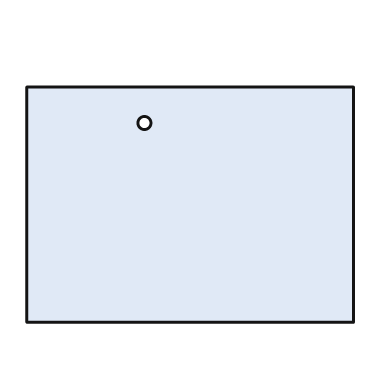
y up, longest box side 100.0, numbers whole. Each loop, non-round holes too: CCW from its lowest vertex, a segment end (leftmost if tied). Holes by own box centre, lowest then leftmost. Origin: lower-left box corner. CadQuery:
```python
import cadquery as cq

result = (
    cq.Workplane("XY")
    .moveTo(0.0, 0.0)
    .lineTo(100.0, 0.0)
    .lineTo(100.0, 72.0)
    .lineTo(0.0, 72.0)
    .close()
    .moveTo(36.0, 61.0)
    .circle(2.0)
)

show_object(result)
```